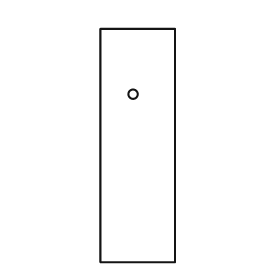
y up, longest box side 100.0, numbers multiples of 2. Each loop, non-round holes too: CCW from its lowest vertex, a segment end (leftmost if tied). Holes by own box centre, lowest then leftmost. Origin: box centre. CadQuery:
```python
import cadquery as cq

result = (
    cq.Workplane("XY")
    .moveTo(-16.0, -50.0)
    .lineTo(16.0, -50.0)
    .lineTo(16.0, 50.0)
    .lineTo(-16.0, 50.0)
    .close()
    .moveTo(-2.0, 22.0)
    .circle(2.0)
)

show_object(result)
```